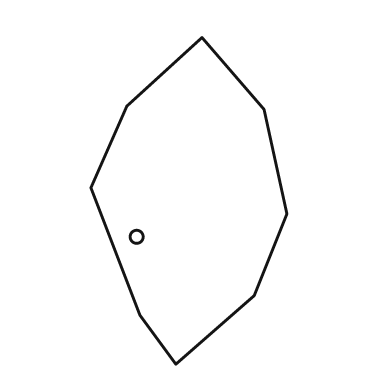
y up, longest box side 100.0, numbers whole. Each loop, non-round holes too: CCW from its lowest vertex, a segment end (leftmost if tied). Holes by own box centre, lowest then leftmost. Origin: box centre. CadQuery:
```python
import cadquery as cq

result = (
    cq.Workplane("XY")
    .moveTo(-4.0, -50.0)
    .lineTo(20.0, -29.0)
    .lineTo(30.0, -4.0)
    .lineTo(23.0, 28.0)
    .lineTo(4.0, 50.0)
    .lineTo(-19.0, 29.0)
    .lineTo(-30.0, 4.0)
    .lineTo(-15.0, -35.0)
    .close()
    .moveTo(-16.0, -11.0)
    .circle(2.0)
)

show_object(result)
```